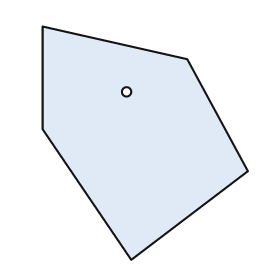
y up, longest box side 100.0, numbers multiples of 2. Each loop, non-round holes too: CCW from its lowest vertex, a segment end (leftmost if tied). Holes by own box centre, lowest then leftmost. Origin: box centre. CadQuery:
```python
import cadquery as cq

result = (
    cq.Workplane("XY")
    .moveTo(-6.0, -50.0)
    .lineTo(44.0, -12.0)
    .lineTo(18.0, 36.0)
    .lineTo(-44.0, 50.0)
    .lineTo(-44.0, 6.0)
    .close()
    .moveTo(-8.0, 22.0)
    .circle(2.0)
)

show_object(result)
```